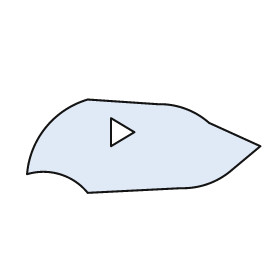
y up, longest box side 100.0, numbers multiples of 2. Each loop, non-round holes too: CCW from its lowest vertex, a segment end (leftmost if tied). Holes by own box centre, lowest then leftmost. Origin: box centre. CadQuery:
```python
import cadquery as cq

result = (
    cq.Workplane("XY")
    .moveTo(-24.0, -20.0)
    .lineTo(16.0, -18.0)
    .threePointArc((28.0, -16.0), (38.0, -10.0))
    .lineTo(50.0, 0.0)
    .lineTo(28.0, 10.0)
    .threePointArc((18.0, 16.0), (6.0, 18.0))
    .lineTo(-24.0, 20.0)
    .threePointArc((-42.0, 8.0), (-50.0, -12.0))
    .threePointArc((-36.0, -12.0), (-24.0, -20.0))
    .close()
    .moveTo(-14.0, 0.0)
    .lineTo(-4.0, 6.0)
    .lineTo(-14.0, 12.0)
    .close()
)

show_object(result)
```